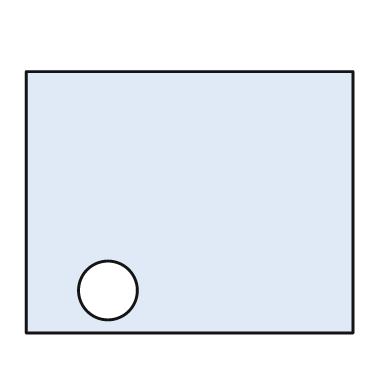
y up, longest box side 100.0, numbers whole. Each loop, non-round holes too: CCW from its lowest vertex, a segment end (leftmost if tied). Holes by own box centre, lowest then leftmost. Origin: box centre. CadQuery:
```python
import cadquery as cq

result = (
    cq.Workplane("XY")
    .moveTo(-50.0, -40.0)
    .lineTo(50.0, -40.0)
    .lineTo(50.0, 40.0)
    .lineTo(-50.0, 40.0)
    .close()
    .moveTo(-25.0, -27.0)
    .circle(9.0)
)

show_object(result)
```